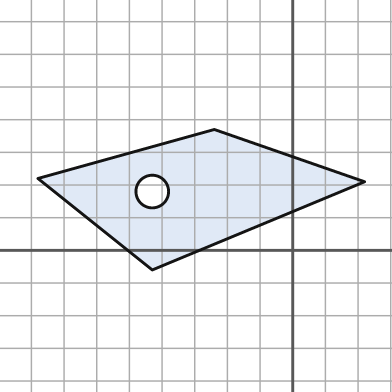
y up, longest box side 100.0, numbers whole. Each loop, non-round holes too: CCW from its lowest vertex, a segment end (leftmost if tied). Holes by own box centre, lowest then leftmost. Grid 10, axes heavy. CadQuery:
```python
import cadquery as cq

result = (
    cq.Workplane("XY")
    .moveTo(-43.0, -6.0)
    .lineTo(22.0, 21.0)
    .lineTo(-24.0, 37.0)
    .lineTo(-78.0, 22.0)
    .close()
    .moveTo(-43.0, 18.0)
    .circle(5.0)
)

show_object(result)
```